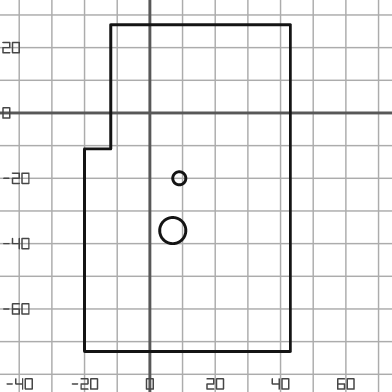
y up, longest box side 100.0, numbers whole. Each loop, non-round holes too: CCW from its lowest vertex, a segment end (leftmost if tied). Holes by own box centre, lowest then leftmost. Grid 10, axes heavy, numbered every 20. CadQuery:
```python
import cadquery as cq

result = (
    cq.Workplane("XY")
    .moveTo(-20.0, -73.0)
    .lineTo(43.0, -73.0)
    .lineTo(43.0, 27.0)
    .lineTo(-12.0, 27.0)
    .lineTo(-12.0, -11.0)
    .lineTo(-20.0, -11.0)
    .close()
    .moveTo(7.0, -36.0)
    .circle(4.0)
    .moveTo(9.0, -20.0)
    .circle(2.0)
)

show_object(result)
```